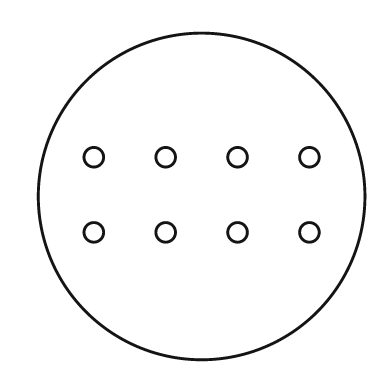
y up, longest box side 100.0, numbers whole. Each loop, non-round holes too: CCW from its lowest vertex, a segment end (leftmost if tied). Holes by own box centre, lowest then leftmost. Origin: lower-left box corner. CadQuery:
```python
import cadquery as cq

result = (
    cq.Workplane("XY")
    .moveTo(50.0, 50.0)
    .circle(50.0)
    .moveTo(17.0, 39.0)
    .circle(3.0)
    .moveTo(39.0, 39.0)
    .circle(3.0)
    .moveTo(61.0, 39.0)
    .circle(3.0)
    .moveTo(83.0, 39.0)
    .circle(3.0)
    .moveTo(17.0, 62.0)
    .circle(3.0)
    .moveTo(39.0, 62.0)
    .circle(3.0)
    .moveTo(61.0, 62.0)
    .circle(3.0)
    .moveTo(83.0, 62.0)
    .circle(3.0)
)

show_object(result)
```